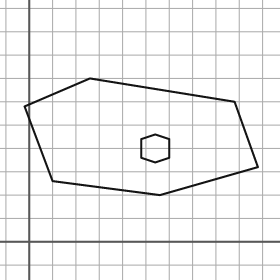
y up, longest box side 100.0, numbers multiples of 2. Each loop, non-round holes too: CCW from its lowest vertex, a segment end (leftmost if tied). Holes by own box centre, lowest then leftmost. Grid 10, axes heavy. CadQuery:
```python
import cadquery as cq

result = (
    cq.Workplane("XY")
    .moveTo(56.0, 20.0)
    .lineTo(98.0, 32.0)
    .lineTo(88.0, 60.0)
    .lineTo(26.0, 70.0)
    .lineTo(-2.0, 58.0)
    .lineTo(10.0, 26.0)
    .close()
    .moveTo(54.0, 34.0)
    .lineTo(60.0, 36.0)
    .lineTo(60.0, 44.0)
    .lineTo(54.0, 46.0)
    .lineTo(48.0, 44.0)
    .lineTo(48.0, 36.0)
    .close()
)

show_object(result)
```